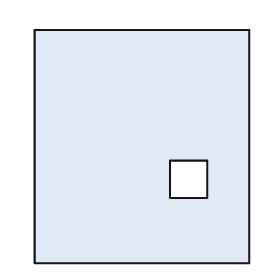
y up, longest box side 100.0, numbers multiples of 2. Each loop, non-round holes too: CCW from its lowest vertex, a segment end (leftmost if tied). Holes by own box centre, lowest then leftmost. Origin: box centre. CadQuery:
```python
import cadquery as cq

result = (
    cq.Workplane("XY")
    .moveTo(-46.0, -50.0)
    .lineTo(46.0, -50.0)
    .lineTo(46.0, 50.0)
    .lineTo(-46.0, 50.0)
    .close()
    .moveTo(12.0, -22.0)
    .lineTo(28.0, -22.0)
    .lineTo(28.0, -6.0)
    .lineTo(12.0, -6.0)
    .close()
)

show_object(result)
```